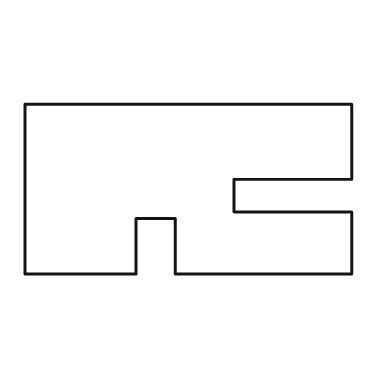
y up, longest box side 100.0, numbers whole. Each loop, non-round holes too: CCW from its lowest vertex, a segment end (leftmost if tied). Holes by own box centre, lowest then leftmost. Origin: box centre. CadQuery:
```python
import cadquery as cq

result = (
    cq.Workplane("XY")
    .moveTo(-50.0, -26.0)
    .lineTo(-16.0, -26.0)
    .lineTo(-16.0, -9.0)
    .lineTo(-4.0, -9.0)
    .lineTo(-4.0, -26.0)
    .lineTo(50.0, -26.0)
    .lineTo(50.0, -7.0)
    .lineTo(14.0, -7.0)
    .lineTo(14.0, 3.0)
    .lineTo(50.0, 3.0)
    .lineTo(50.0, 26.0)
    .lineTo(-50.0, 26.0)
    .close()
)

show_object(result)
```